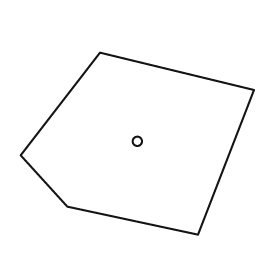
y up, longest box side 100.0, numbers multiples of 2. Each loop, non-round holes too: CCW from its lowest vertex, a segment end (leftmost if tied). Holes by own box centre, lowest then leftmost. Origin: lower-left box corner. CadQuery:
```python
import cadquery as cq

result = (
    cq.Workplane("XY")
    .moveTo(76.0, 0.0)
    .lineTo(100.0, 62.0)
    .lineTo(34.0, 78.0)
    .lineTo(0.0, 34.0)
    .lineTo(20.0, 12.0)
    .close()
    .moveTo(50.0, 40.0)
    .circle(2.0)
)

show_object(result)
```